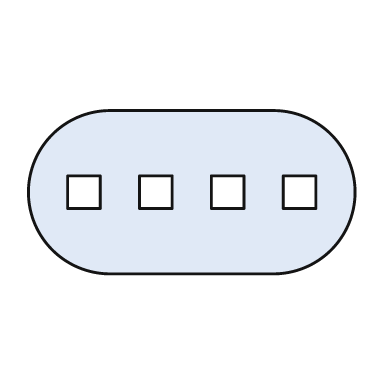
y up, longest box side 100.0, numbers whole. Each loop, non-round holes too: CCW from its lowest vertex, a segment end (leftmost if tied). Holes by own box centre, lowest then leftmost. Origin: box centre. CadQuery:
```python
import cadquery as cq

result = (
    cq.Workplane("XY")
    .moveTo(-25.0, -25.0)
    .lineTo(25.0, -25.0)
    .threePointArc((50.0, 0.0), (25.0, 25.0))
    .lineTo(-25.0, 25.0)
    .threePointArc((-50.0, 0.0), (-25.0, -25.0))
    .close()
    .moveTo(-38.0, -5.0)
    .lineTo(-28.0, -5.0)
    .lineTo(-28.0, 5.0)
    .lineTo(-38.0, 5.0)
    .close()
    .moveTo(-16.0, -5.0)
    .lineTo(-6.0, -5.0)
    .lineTo(-6.0, 5.0)
    .lineTo(-16.0, 5.0)
    .close()
    .moveTo(6.0, -5.0)
    .lineTo(16.0, -5.0)
    .lineTo(16.0, 5.0)
    .lineTo(6.0, 5.0)
    .close()
    .moveTo(28.0, -5.0)
    .lineTo(38.0, -5.0)
    .lineTo(38.0, 5.0)
    .lineTo(28.0, 5.0)
    .close()
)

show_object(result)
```